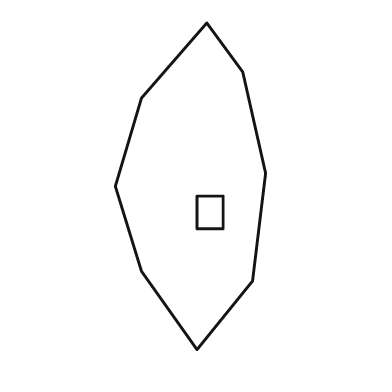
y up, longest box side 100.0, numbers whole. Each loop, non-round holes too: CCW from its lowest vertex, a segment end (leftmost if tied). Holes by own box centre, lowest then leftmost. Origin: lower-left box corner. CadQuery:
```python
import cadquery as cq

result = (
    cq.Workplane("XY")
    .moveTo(25.0, 0.0)
    .lineTo(42.0, 21.0)
    .lineTo(46.0, 54.0)
    .lineTo(39.0, 85.0)
    .lineTo(28.0, 100.0)
    .lineTo(8.0, 77.0)
    .lineTo(0.0, 50.0)
    .lineTo(8.0, 24.0)
    .close()
    .moveTo(25.0, 37.0)
    .lineTo(33.0, 37.0)
    .lineTo(33.0, 47.0)
    .lineTo(25.0, 47.0)
    .close()
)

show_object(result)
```